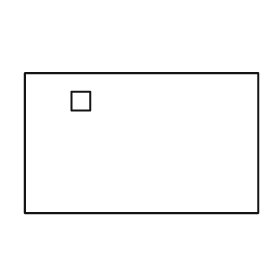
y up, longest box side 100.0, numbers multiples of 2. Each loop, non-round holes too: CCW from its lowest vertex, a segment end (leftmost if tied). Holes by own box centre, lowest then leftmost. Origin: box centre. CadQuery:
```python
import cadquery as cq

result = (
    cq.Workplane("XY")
    .moveTo(-50.0, -30.0)
    .lineTo(50.0, -30.0)
    .lineTo(50.0, 30.0)
    .lineTo(-50.0, 30.0)
    .close()
    .moveTo(-30.0, 14.0)
    .lineTo(-22.0, 14.0)
    .lineTo(-22.0, 22.0)
    .lineTo(-30.0, 22.0)
    .close()
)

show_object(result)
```